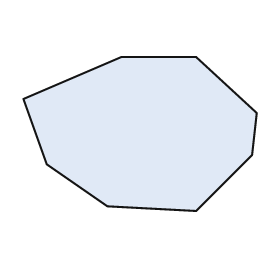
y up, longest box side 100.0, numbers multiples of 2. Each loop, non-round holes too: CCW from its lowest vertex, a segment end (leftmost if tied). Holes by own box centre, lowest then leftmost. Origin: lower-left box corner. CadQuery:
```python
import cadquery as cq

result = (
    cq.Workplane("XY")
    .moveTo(74.0, 0.0)
    .lineTo(98.0, 24.0)
    .lineTo(100.0, 42.0)
    .lineTo(74.0, 66.0)
    .lineTo(42.0, 66.0)
    .lineTo(0.0, 48.0)
    .lineTo(10.0, 20.0)
    .lineTo(36.0, 2.0)
    .close()
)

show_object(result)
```